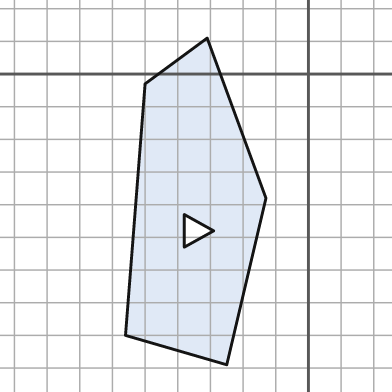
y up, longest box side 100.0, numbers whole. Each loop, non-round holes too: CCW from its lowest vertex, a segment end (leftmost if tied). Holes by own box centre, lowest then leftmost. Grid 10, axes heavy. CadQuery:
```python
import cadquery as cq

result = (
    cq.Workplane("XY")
    .moveTo(-25.0, -89.0)
    .lineTo(-13.0, -38.0)
    .lineTo(-31.0, 11.0)
    .lineTo(-50.0, -3.0)
    .lineTo(-56.0, -80.0)
    .close()
    .moveTo(-38.0, -53.0)
    .lineTo(-29.0, -48.0)
    .lineTo(-38.0, -43.0)
    .close()
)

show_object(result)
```